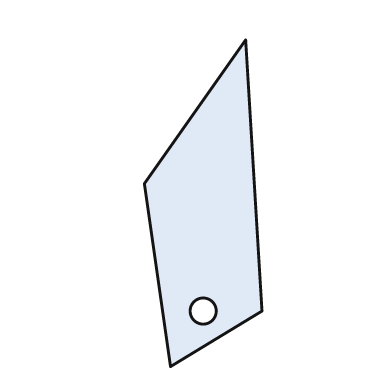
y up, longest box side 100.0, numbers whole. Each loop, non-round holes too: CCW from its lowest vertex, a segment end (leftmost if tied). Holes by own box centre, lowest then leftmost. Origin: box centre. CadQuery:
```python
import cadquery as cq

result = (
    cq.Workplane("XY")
    .moveTo(-10.0, -50.0)
    .lineTo(18.0, -33.0)
    .lineTo(13.0, 50.0)
    .lineTo(-18.0, 6.0)
    .close()
    .moveTo(0.0, -33.0)
    .circle(4.0)
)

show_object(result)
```